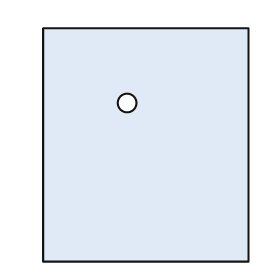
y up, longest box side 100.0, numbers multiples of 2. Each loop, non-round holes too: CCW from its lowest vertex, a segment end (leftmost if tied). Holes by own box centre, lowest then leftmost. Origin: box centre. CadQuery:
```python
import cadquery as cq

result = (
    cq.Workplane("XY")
    .moveTo(-44.0, -50.0)
    .lineTo(44.0, -50.0)
    .lineTo(44.0, 50.0)
    .lineTo(-44.0, 50.0)
    .close()
    .moveTo(-8.0, 18.0)
    .circle(4.0)
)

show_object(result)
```